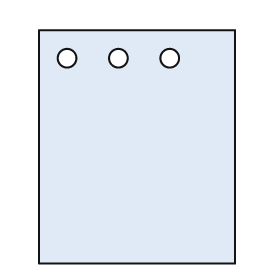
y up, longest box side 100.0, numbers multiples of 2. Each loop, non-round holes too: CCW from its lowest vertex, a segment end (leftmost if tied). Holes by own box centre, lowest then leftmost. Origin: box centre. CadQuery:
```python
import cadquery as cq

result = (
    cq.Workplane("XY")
    .moveTo(-42.0, -50.0)
    .lineTo(42.0, -50.0)
    .lineTo(42.0, 50.0)
    .lineTo(-42.0, 50.0)
    .close()
    .moveTo(-30.0, 38.0)
    .circle(4.0)
    .moveTo(-8.0, 38.0)
    .circle(4.0)
    .moveTo(14.0, 38.0)
    .circle(4.0)
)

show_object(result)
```